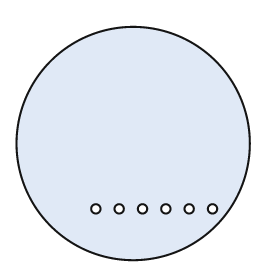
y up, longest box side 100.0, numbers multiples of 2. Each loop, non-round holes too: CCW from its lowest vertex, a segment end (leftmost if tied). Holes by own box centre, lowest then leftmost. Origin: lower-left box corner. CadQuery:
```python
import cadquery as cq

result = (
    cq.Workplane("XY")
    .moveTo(50.0, 50.0)
    .circle(50.0)
    .moveTo(34.0, 22.0)
    .circle(2.0)
    .moveTo(44.0, 22.0)
    .circle(2.0)
    .moveTo(54.0, 22.0)
    .circle(2.0)
    .moveTo(64.0, 22.0)
    .circle(2.0)
    .moveTo(74.0, 22.0)
    .circle(2.0)
    .moveTo(84.0, 22.0)
    .circle(2.0)
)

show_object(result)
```